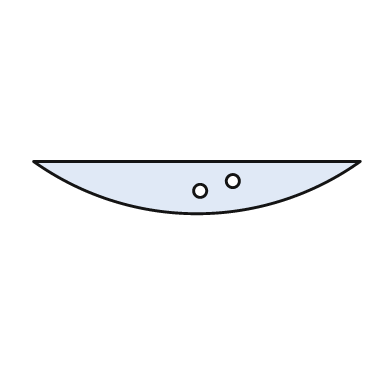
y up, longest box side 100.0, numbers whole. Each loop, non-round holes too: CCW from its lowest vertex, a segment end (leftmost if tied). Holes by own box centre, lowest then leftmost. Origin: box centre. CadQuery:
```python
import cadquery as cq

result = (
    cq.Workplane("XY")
    .moveTo(-50.0, 8.0)
    .threePointArc((0.0, -8.0), (50.0, 8.0))
    .close()
    .moveTo(1.0, -1.0)
    .circle(2.0)
    .moveTo(11.0, 2.0)
    .circle(2.0)
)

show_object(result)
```